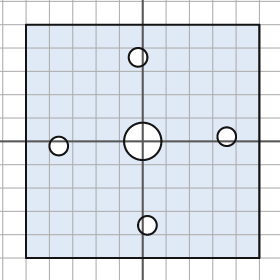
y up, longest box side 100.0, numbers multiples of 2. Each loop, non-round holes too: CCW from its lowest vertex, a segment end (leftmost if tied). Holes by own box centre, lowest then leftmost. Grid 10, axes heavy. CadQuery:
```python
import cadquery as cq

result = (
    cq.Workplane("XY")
    .moveTo(-50.0, -50.0)
    .lineTo(50.0, -50.0)
    .lineTo(50.0, 50.0)
    .lineTo(-50.0, 50.0)
    .close()
    .moveTo(2.0, -36.0)
    .circle(4.0)
    .moveTo(-36.0, -2.0)
    .circle(4.0)
    .moveTo(0.0, 0.0)
    .circle(8.0)
    .moveTo(36.0, 2.0)
    .circle(4.0)
    .moveTo(-2.0, 36.0)
    .circle(4.0)
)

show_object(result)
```